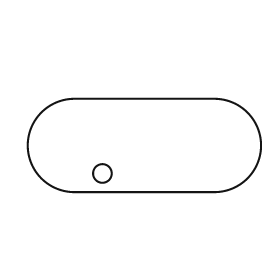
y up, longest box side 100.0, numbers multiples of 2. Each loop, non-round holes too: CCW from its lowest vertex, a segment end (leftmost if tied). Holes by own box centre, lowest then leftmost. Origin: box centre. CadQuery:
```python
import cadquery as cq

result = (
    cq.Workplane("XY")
    .moveTo(-30.0, -20.0)
    .lineTo(30.0, -20.0)
    .threePointArc((50.0, 0.0), (30.0, 20.0))
    .lineTo(-30.0, 20.0)
    .threePointArc((-50.0, 0.0), (-30.0, -20.0))
    .close()
    .moveTo(-18.0, -12.0)
    .circle(4.0)
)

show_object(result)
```